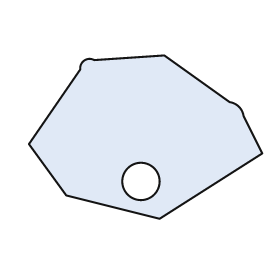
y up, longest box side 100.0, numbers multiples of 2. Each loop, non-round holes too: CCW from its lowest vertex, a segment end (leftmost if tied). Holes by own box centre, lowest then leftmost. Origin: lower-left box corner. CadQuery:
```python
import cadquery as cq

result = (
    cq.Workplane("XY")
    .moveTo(56.0, 0.0)
    .lineTo(100.0, 28.0)
    .lineTo(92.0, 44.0)
    .threePointArc((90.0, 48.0), (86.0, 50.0))
    .lineTo(58.0, 70.0)
    .lineTo(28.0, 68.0)
    .threePointArc((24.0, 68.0), (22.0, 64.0))
    .lineTo(0.0, 32.0)
    .lineTo(16.0, 10.0)
    .close()
    .moveTo(48.0, 16.0)
    .circle(8.0)
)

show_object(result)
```